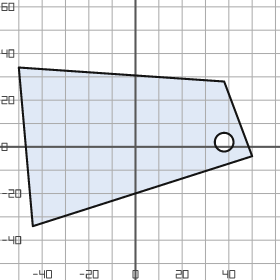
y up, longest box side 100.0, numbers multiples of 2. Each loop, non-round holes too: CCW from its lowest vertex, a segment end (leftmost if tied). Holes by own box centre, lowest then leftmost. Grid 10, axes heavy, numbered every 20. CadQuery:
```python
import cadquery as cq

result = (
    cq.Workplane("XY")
    .moveTo(-44.0, -34.0)
    .lineTo(50.0, -4.0)
    .lineTo(38.0, 28.0)
    .lineTo(-50.0, 34.0)
    .close()
    .moveTo(38.0, 2.0)
    .circle(4.0)
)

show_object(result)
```